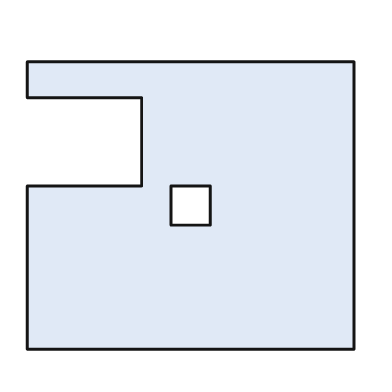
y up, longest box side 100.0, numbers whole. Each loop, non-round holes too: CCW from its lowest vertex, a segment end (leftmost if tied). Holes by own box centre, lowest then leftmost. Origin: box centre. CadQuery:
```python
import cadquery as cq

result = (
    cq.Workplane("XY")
    .moveTo(-50.0, -44.0)
    .lineTo(50.0, -44.0)
    .lineTo(50.0, 44.0)
    .lineTo(-50.0, 44.0)
    .lineTo(-50.0, 33.0)
    .lineTo(-15.0, 33.0)
    .lineTo(-15.0, 6.0)
    .lineTo(-50.0, 6.0)
    .close()
    .moveTo(-6.0, -6.0)
    .lineTo(6.0, -6.0)
    .lineTo(6.0, 6.0)
    .lineTo(-6.0, 6.0)
    .close()
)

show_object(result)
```